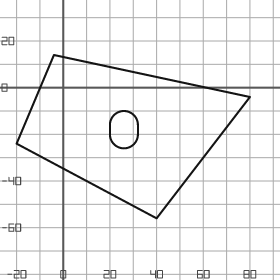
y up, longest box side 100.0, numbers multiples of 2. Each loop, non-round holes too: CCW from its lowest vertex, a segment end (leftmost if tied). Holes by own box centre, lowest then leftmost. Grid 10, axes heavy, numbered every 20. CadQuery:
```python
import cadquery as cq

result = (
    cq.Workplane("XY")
    .moveTo(40.0, -56.0)
    .lineTo(80.0, -4.0)
    .lineTo(-4.0, 14.0)
    .lineTo(-20.0, -24.0)
    .close()
    .moveTo(20.0, -20.0)
    .threePointArc((26.0, -26.0), (32.0, -20.0))
    .lineTo(32.0, -16.0)
    .threePointArc((26.0, -10.0), (20.0, -16.0))
    .close()
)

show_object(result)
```